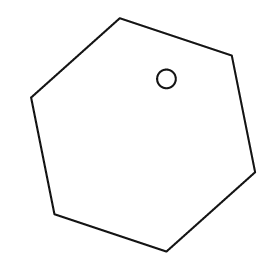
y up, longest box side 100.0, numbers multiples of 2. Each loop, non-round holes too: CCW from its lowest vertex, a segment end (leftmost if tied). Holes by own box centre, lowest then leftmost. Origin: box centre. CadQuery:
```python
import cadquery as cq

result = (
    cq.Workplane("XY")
    .moveTo(10.0, -50.0)
    .lineTo(48.0, -16.0)
    .lineTo(38.0, 34.0)
    .lineTo(-10.0, 50.0)
    .lineTo(-48.0, 16.0)
    .lineTo(-38.0, -34.0)
    .close()
    .moveTo(10.0, 24.0)
    .circle(4.0)
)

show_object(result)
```